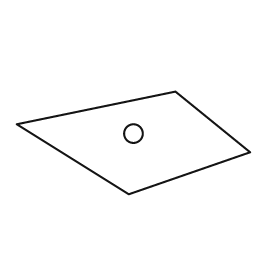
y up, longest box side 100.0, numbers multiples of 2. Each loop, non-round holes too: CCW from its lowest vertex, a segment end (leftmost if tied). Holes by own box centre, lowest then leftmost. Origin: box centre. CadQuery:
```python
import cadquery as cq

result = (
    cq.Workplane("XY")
    .moveTo(-2.0, -22.0)
    .lineTo(50.0, -4.0)
    .lineTo(18.0, 22.0)
    .lineTo(-50.0, 8.0)
    .close()
    .moveTo(0.0, 4.0)
    .circle(4.0)
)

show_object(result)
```